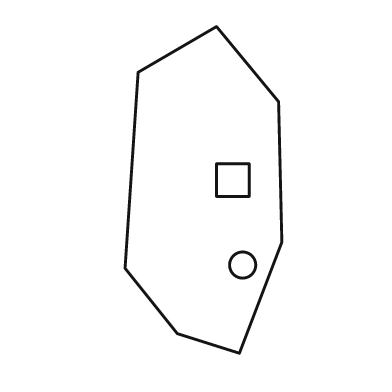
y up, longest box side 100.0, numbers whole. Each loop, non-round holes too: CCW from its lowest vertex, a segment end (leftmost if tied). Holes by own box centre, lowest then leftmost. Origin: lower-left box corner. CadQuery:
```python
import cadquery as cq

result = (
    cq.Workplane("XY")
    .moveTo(35.0, 0.0)
    .lineTo(48.0, 34.0)
    .lineTo(47.0, 77.0)
    .lineTo(28.0, 100.0)
    .lineTo(4.0, 86.0)
    .lineTo(0.0, 26.0)
    .lineTo(16.0, 6.0)
    .close()
    .moveTo(36.0, 27.0)
    .circle(4.0)
    .moveTo(28.0, 48.0)
    .lineTo(38.0, 48.0)
    .lineTo(38.0, 58.0)
    .lineTo(28.0, 58.0)
    .close()
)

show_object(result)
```